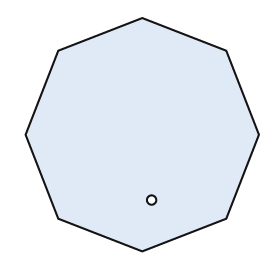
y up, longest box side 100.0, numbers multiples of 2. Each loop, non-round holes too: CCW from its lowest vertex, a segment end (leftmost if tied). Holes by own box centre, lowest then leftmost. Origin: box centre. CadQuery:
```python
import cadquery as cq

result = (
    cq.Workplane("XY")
    .moveTo(0.0, -50.0)
    .lineTo(36.0, -36.0)
    .lineTo(50.0, 0.0)
    .lineTo(36.0, 36.0)
    .lineTo(0.0, 50.0)
    .lineTo(-36.0, 36.0)
    .lineTo(-50.0, 0.0)
    .lineTo(-36.0, -36.0)
    .close()
    .moveTo(4.0, -28.0)
    .circle(2.0)
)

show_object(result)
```